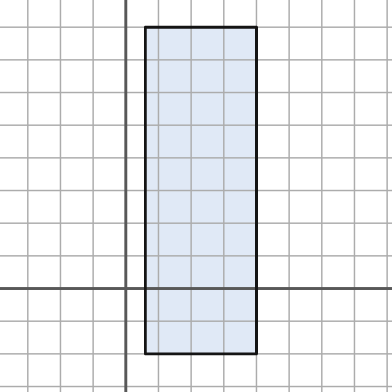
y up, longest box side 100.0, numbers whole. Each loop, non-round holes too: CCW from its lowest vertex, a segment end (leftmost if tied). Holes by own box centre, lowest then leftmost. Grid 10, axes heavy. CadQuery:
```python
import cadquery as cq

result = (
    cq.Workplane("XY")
    .moveTo(6.0, -20.0)
    .lineTo(40.0, -20.0)
    .lineTo(40.0, 80.0)
    .lineTo(6.0, 80.0)
    .close()
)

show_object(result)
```